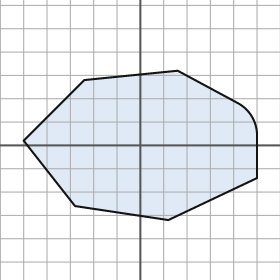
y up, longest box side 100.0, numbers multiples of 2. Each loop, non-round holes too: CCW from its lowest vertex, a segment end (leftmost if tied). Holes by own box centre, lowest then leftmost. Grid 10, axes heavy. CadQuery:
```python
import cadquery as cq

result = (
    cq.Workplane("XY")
    .moveTo(12.0, -32.0)
    .lineTo(50.0, -14.0)
    .lineTo(50.0, 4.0)
    .threePointArc((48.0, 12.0), (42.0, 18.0))
    .lineTo(16.0, 32.0)
    .lineTo(-24.0, 28.0)
    .lineTo(-50.0, 2.0)
    .lineTo(-28.0, -26.0)
    .close()
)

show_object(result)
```